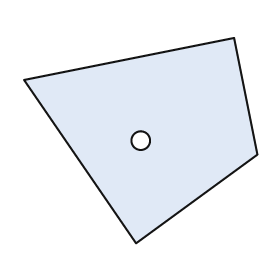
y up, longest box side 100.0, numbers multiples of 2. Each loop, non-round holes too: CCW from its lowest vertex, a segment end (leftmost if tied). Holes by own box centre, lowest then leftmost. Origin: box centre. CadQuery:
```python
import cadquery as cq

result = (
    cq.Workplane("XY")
    .moveTo(-2.0, -44.0)
    .lineTo(50.0, -6.0)
    .lineTo(40.0, 44.0)
    .lineTo(-50.0, 26.0)
    .close()
    .moveTo(0.0, 0.0)
    .circle(4.0)
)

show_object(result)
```